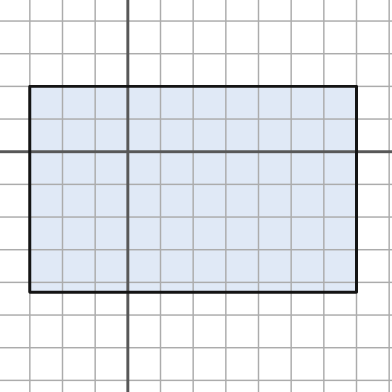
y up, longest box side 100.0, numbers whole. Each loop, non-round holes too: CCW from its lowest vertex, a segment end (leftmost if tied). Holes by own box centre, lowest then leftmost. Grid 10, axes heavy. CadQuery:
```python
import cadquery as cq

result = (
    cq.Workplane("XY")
    .moveTo(-30.0, -43.0)
    .lineTo(70.0, -43.0)
    .lineTo(70.0, 20.0)
    .lineTo(-30.0, 20.0)
    .close()
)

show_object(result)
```